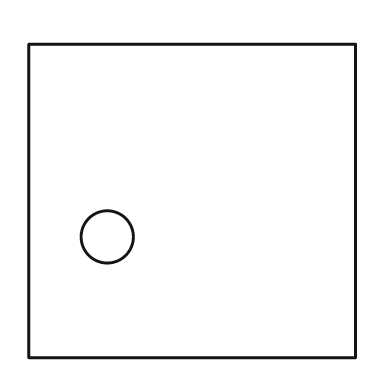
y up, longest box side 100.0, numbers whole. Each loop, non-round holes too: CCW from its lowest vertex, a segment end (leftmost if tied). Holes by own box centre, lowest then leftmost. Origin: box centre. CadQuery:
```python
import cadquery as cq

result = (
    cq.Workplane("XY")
    .moveTo(-50.0, -48.0)
    .lineTo(50.0, -48.0)
    .lineTo(50.0, 48.0)
    .lineTo(-50.0, 48.0)
    .close()
    .moveTo(-26.0, -11.0)
    .circle(8.0)
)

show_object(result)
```